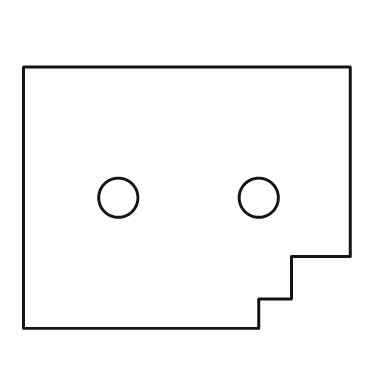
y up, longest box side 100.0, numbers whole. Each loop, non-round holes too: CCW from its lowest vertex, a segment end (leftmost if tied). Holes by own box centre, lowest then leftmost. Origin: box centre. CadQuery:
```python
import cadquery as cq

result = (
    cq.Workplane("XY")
    .moveTo(-50.0, -40.0)
    .lineTo(22.0, -40.0)
    .lineTo(22.0, -31.0)
    .lineTo(32.0, -31.0)
    .lineTo(32.0, -18.0)
    .lineTo(50.0, -18.0)
    .lineTo(50.0, 40.0)
    .lineTo(-50.0, 40.0)
    .close()
    .moveTo(-21.0, 0.0)
    .circle(6.0)
    .moveTo(22.0, 0.0)
    .circle(6.0)
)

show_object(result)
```